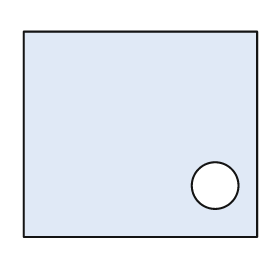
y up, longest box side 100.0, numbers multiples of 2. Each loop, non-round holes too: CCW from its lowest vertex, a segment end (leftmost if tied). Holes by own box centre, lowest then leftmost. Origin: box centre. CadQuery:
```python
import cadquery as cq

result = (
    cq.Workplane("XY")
    .moveTo(-50.0, -44.0)
    .lineTo(50.0, -44.0)
    .lineTo(50.0, 44.0)
    .lineTo(-50.0, 44.0)
    .close()
    .moveTo(32.0, -22.0)
    .circle(10.0)
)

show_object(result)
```